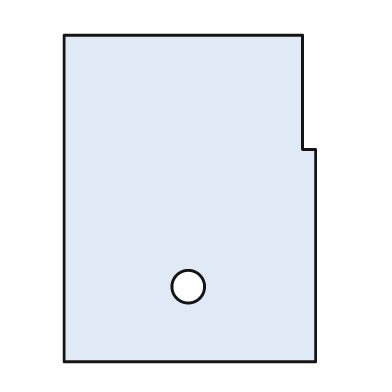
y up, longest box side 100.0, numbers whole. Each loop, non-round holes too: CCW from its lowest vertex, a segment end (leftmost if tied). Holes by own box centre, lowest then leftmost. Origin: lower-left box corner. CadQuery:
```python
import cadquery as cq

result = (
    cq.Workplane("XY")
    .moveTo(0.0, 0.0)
    .lineTo(77.0, 0.0)
    .lineTo(77.0, 65.0)
    .lineTo(73.0, 65.0)
    .lineTo(73.0, 100.0)
    .lineTo(0.0, 100.0)
    .close()
    .moveTo(38.0, 23.0)
    .circle(5.0)
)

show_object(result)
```